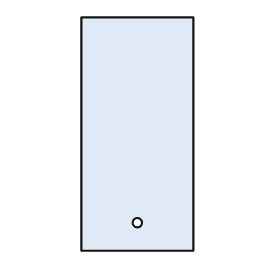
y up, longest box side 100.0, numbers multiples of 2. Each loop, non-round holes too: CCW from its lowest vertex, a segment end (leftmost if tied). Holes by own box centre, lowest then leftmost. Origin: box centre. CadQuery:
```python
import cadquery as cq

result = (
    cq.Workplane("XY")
    .moveTo(-24.0, -50.0)
    .lineTo(24.0, -50.0)
    .lineTo(24.0, 50.0)
    .lineTo(-24.0, 50.0)
    .close()
    .moveTo(0.0, -38.0)
    .circle(2.0)
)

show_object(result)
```